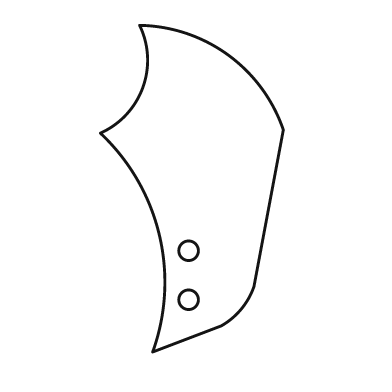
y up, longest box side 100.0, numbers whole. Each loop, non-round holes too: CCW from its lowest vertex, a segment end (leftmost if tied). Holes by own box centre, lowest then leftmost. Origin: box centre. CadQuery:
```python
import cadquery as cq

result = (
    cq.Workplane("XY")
    .moveTo(-12.0, -50.0)
    .lineTo(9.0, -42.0)
    .threePointArc((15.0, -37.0), (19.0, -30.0))
    .lineTo(28.0, 18.0)
    .threePointArc((11.0, 41.0), (-16.0, 50.0))
    .threePointArc((-15.0, 31.0), (-28.0, 17.0))
    .threePointArc((-10.0, -14.0), (-12.0, -50.0))
    .close()
    .moveTo(-1.0, -34.0)
    .circle(3.0)
    .moveTo(-1.0, -19.0)
    .circle(3.0)
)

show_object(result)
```